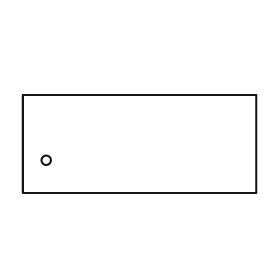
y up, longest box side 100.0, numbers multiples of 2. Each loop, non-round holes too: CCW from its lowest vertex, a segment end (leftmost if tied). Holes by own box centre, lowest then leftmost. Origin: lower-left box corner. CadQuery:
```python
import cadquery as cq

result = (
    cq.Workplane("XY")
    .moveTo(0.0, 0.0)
    .lineTo(100.0, 0.0)
    .lineTo(100.0, 42.0)
    .lineTo(0.0, 42.0)
    .close()
    .moveTo(10.0, 14.0)
    .circle(2.0)
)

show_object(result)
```